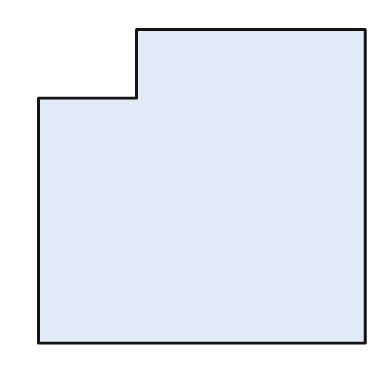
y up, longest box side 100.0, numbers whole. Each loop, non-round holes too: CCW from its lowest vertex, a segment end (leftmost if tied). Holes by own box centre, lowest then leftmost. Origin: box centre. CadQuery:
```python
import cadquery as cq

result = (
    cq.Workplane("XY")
    .moveTo(-50.0, -48.0)
    .lineTo(50.0, -48.0)
    .lineTo(50.0, 48.0)
    .lineTo(-20.0, 48.0)
    .lineTo(-20.0, 27.0)
    .lineTo(-50.0, 27.0)
    .close()
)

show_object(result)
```